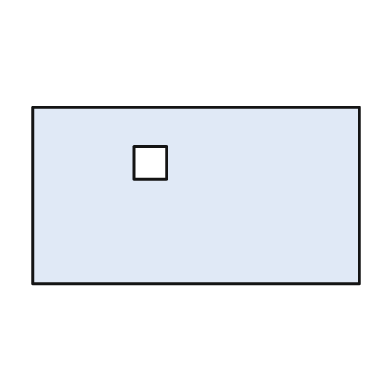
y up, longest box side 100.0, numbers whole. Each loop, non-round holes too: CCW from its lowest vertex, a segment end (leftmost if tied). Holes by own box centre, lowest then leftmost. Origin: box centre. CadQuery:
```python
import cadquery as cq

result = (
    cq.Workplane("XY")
    .moveTo(-50.0, -27.0)
    .lineTo(50.0, -27.0)
    .lineTo(50.0, 27.0)
    .lineTo(-50.0, 27.0)
    .close()
    .moveTo(-19.0, 5.0)
    .lineTo(-9.0, 5.0)
    .lineTo(-9.0, 15.0)
    .lineTo(-19.0, 15.0)
    .close()
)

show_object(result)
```